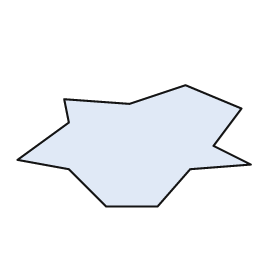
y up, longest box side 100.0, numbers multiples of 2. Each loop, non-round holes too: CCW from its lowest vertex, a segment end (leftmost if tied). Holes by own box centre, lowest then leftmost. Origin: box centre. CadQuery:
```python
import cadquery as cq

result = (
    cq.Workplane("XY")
    .moveTo(-12.0, -26.0)
    .lineTo(10.0, -26.0)
    .lineTo(24.0, -10.0)
    .lineTo(50.0, -8.0)
    .lineTo(34.0, 0.0)
    .lineTo(46.0, 16.0)
    .lineTo(22.0, 26.0)
    .lineTo(-2.0, 18.0)
    .lineTo(-30.0, 20.0)
    .lineTo(-28.0, 10.0)
    .lineTo(-50.0, -6.0)
    .lineTo(-28.0, -10.0)
    .close()
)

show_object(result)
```